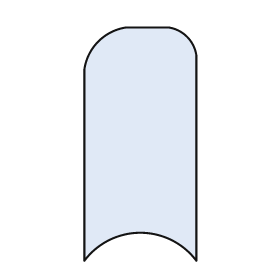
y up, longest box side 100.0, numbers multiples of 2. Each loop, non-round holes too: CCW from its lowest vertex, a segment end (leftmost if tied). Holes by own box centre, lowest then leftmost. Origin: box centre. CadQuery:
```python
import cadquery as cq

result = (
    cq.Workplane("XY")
    .moveTo(-24.0, -50.0)
    .threePointArc((0.0, -38.0), (24.0, -50.0))
    .lineTo(24.0, 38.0)
    .threePointArc((20.0, 46.0), (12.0, 50.0))
    .lineTo(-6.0, 50.0)
    .threePointArc((-18.0, 44.0), (-24.0, 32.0))
    .close()
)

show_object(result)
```